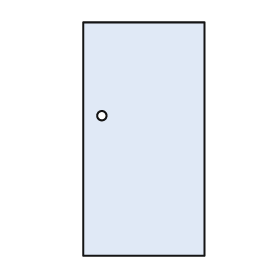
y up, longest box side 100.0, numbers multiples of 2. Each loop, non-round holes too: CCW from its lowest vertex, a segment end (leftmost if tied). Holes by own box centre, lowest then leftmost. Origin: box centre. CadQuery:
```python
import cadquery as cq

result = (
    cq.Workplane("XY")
    .moveTo(-26.0, -50.0)
    .lineTo(26.0, -50.0)
    .lineTo(26.0, 50.0)
    .lineTo(-26.0, 50.0)
    .close()
    .moveTo(-18.0, 10.0)
    .circle(2.0)
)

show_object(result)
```